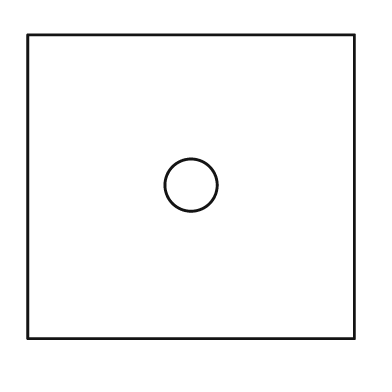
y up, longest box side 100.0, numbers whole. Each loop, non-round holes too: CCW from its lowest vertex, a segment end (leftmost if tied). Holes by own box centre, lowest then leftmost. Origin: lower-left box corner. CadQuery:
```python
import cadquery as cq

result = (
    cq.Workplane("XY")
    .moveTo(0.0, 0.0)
    .lineTo(100.0, 0.0)
    .lineTo(100.0, 93.0)
    .lineTo(0.0, 93.0)
    .close()
    .moveTo(50.0, 47.0)
    .circle(8.0)
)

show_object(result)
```